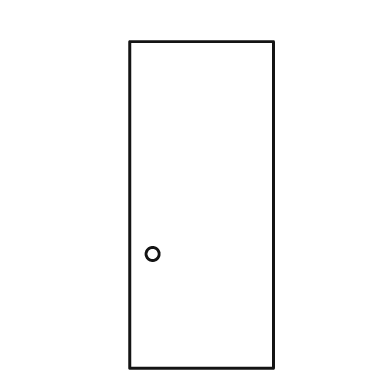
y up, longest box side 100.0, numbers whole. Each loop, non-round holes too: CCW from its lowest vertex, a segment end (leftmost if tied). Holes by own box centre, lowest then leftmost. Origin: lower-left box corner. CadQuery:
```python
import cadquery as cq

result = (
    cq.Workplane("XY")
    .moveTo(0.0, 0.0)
    .lineTo(44.0, 0.0)
    .lineTo(44.0, 100.0)
    .lineTo(0.0, 100.0)
    .close()
    .moveTo(7.0, 35.0)
    .circle(2.0)
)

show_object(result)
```